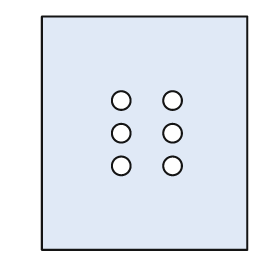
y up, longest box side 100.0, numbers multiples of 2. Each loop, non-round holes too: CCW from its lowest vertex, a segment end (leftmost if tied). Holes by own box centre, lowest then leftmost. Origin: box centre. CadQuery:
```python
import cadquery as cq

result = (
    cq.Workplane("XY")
    .moveTo(-44.0, -50.0)
    .lineTo(44.0, -50.0)
    .lineTo(44.0, 50.0)
    .lineTo(-44.0, 50.0)
    .close()
    .moveTo(-10.0, -14.0)
    .circle(4.0)
    .moveTo(12.0, -14.0)
    .circle(4.0)
    .moveTo(-10.0, 0.0)
    .circle(4.0)
    .moveTo(12.0, 0.0)
    .circle(4.0)
    .moveTo(-10.0, 14.0)
    .circle(4.0)
    .moveTo(12.0, 14.0)
    .circle(4.0)
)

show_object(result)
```